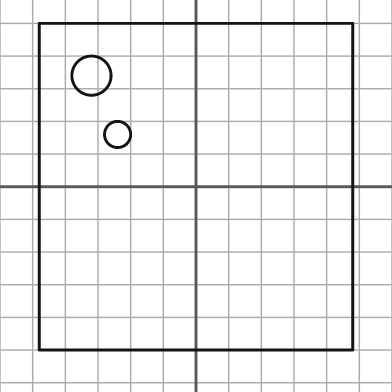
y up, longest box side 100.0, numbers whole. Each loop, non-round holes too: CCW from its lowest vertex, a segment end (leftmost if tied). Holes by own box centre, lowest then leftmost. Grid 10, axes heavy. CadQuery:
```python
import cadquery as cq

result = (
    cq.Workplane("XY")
    .moveTo(-48.0, -50.0)
    .lineTo(48.0, -50.0)
    .lineTo(48.0, 50.0)
    .lineTo(-48.0, 50.0)
    .close()
    .moveTo(-24.0, 16.0)
    .circle(4.0)
    .moveTo(-32.0, 34.0)
    .circle(6.0)
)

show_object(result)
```